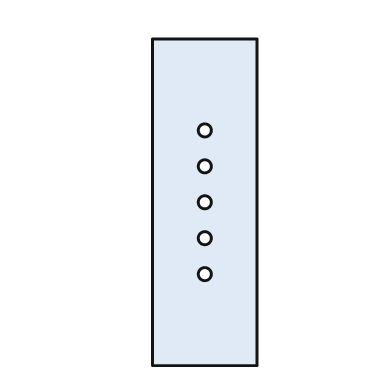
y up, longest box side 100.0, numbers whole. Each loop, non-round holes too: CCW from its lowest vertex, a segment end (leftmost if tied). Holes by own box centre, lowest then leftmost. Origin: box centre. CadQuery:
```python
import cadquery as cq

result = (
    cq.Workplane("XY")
    .moveTo(-16.0, -50.0)
    .lineTo(16.0, -50.0)
    .lineTo(16.0, 50.0)
    .lineTo(-16.0, 50.0)
    .close()
    .moveTo(0.0, -22.0)
    .circle(2.0)
    .moveTo(0.0, -11.0)
    .circle(2.0)
    .moveTo(0.0, 0.0)
    .circle(2.0)
    .moveTo(0.0, 11.0)
    .circle(2.0)
    .moveTo(0.0, 22.0)
    .circle(2.0)
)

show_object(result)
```